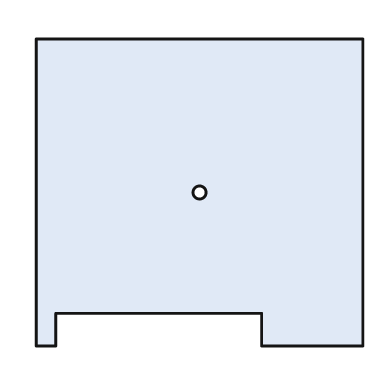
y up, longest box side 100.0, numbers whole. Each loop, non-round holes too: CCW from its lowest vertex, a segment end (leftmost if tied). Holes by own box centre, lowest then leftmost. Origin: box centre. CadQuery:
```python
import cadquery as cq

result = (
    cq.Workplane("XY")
    .moveTo(-50.0, -47.0)
    .lineTo(-44.0, -47.0)
    .lineTo(-44.0, -37.0)
    .lineTo(19.0, -37.0)
    .lineTo(19.0, -47.0)
    .lineTo(50.0, -47.0)
    .lineTo(50.0, 47.0)
    .lineTo(-50.0, 47.0)
    .close()
    .moveTo(0.0, 0.0)
    .circle(2.0)
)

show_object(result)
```